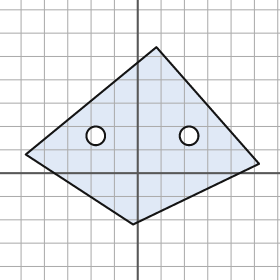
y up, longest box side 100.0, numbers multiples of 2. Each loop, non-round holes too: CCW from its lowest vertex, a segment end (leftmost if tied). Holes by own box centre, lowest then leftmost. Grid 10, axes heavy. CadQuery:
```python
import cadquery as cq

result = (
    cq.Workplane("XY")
    .moveTo(-2.0, -22.0)
    .lineTo(52.0, 4.0)
    .lineTo(8.0, 54.0)
    .lineTo(-48.0, 8.0)
    .close()
    .moveTo(-18.0, 16.0)
    .circle(4.0)
    .moveTo(22.0, 16.0)
    .circle(4.0)
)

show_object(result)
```